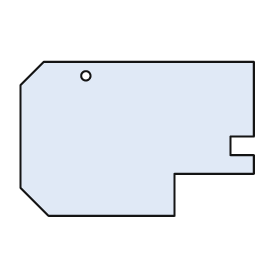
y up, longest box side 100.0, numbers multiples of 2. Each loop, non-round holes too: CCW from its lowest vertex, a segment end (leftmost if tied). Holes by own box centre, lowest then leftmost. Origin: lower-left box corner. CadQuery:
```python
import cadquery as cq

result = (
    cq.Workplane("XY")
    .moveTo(12.0, 0.0)
    .lineTo(66.0, 0.0)
    .lineTo(66.0, 18.0)
    .lineTo(100.0, 18.0)
    .lineTo(100.0, 26.0)
    .lineTo(90.0, 26.0)
    .lineTo(90.0, 34.0)
    .lineTo(100.0, 34.0)
    .lineTo(100.0, 66.0)
    .lineTo(10.0, 66.0)
    .lineTo(0.0, 56.0)
    .lineTo(0.0, 12.0)
    .close()
    .moveTo(28.0, 60.0)
    .circle(2.0)
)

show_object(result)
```